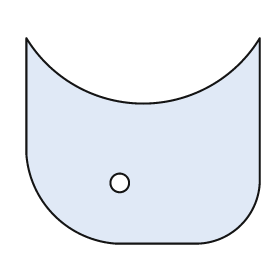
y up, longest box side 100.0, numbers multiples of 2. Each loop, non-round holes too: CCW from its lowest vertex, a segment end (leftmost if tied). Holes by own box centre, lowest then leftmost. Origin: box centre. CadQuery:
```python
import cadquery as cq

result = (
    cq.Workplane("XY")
    .moveTo(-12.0, -44.0)
    .lineTo(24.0, -44.0)
    .threePointArc((42.0, -36.0), (50.0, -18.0))
    .lineTo(50.0, 44.0)
    .threePointArc((0.0, 16.0), (-50.0, 44.0))
    .lineTo(-50.0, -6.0)
    .threePointArc((-38.0, -32.0), (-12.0, -44.0))
    .close()
    .moveTo(-10.0, -18.0)
    .circle(4.0)
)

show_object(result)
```